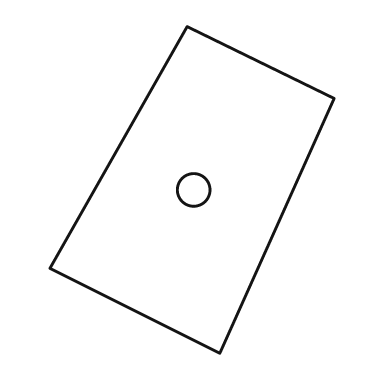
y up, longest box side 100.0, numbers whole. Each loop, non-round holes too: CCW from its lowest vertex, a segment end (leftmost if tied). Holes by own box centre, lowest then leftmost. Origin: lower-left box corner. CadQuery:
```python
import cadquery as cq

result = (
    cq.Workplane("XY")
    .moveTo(52.0, 0.0)
    .lineTo(87.0, 78.0)
    .lineTo(42.0, 100.0)
    .lineTo(0.0, 26.0)
    .close()
    .moveTo(44.0, 50.0)
    .circle(5.0)
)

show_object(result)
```